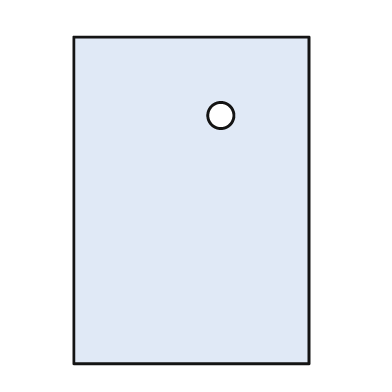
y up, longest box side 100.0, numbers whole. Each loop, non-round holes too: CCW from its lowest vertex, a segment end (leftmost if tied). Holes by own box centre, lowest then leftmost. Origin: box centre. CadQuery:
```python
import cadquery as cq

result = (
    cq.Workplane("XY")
    .moveTo(-36.0, -50.0)
    .lineTo(36.0, -50.0)
    .lineTo(36.0, 50.0)
    .lineTo(-36.0, 50.0)
    .close()
    .moveTo(9.0, 26.0)
    .circle(4.0)
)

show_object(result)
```